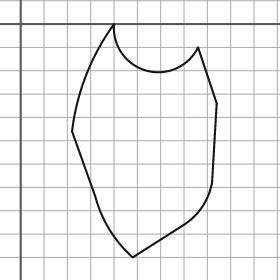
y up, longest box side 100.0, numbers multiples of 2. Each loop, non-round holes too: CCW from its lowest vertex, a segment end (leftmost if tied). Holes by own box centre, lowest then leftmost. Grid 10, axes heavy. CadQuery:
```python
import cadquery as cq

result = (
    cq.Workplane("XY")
    .moveTo(48.0, -100.0)
    .lineTo(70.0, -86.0)
    .threePointArc((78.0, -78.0), (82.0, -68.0))
    .lineTo(84.0, -34.0)
    .lineTo(76.0, -10.0)
    .threePointArc((54.0, -20.0), (40.0, 0.0))
    .threePointArc((28.0, -22.0), (22.0, -46.0))
    .lineTo(32.0, -74.0)
    .threePointArc((38.0, -88.0), (48.0, -100.0))
    .close()
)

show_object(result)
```